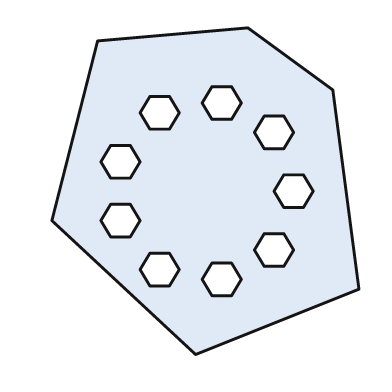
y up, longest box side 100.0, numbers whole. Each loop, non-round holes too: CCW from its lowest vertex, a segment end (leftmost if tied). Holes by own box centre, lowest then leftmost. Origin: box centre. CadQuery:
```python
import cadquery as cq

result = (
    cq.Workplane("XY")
    .moveTo(-3.0, -50.0)
    .lineTo(47.0, -30.0)
    .lineTo(39.0, 31.0)
    .lineTo(13.0, 50.0)
    .lineTo(-33.0, 46.0)
    .lineTo(-47.0, -9.0)
    .close()
    .moveTo(2.0, -32.0)
    .lineTo(8.0, -32.0)
    .lineTo(11.0, -27.0)
    .lineTo(8.0, -22.0)
    .lineTo(2.0, -22.0)
    .lineTo(-1.0, -27.0)
    .close()
    .moveTo(-17.0, -29.0)
    .lineTo(-11.0, -29.0)
    .lineTo(-8.0, -24.0)
    .lineTo(-11.0, -19.0)
    .lineTo(-17.0, -19.0)
    .lineTo(-20.0, -24.0)
    .close()
    .moveTo(18.0, -23.0)
    .lineTo(24.0, -23.0)
    .lineTo(27.0, -18.0)
    .lineTo(24.0, -13.0)
    .lineTo(18.0, -13.0)
    .lineTo(15.0, -18.0)
    .close()
    .moveTo(-29.0, -14.0)
    .lineTo(-23.0, -14.0)
    .lineTo(-20.0, -9.0)
    .lineTo(-23.0, -4.0)
    .lineTo(-29.0, -4.0)
    .lineTo(-32.0, -9.0)
    .close()
    .moveTo(24.0, -5.0)
    .lineTo(30.0, -5.0)
    .lineTo(33.0, 0.0)
    .lineTo(30.0, 5.0)
    .lineTo(24.0, 5.0)
    .lineTo(21.0, 0.0)
    .close()
    .moveTo(-29.0, 4.0)
    .lineTo(-23.0, 4.0)
    .lineTo(-20.0, 9.0)
    .lineTo(-23.0, 14.0)
    .lineTo(-29.0, 14.0)
    .lineTo(-32.0, 9.0)
    .close()
    .moveTo(18.0, 13.0)
    .lineTo(24.0, 13.0)
    .lineTo(27.0, 18.0)
    .lineTo(24.0, 23.0)
    .lineTo(18.0, 23.0)
    .lineTo(15.0, 18.0)
    .close()
    .moveTo(-17.0, 19.0)
    .lineTo(-11.0, 19.0)
    .lineTo(-8.0, 24.0)
    .lineTo(-11.0, 29.0)
    .lineTo(-17.0, 29.0)
    .lineTo(-20.0, 24.0)
    .close()
    .moveTo(2.0, 22.0)
    .lineTo(8.0, 22.0)
    .lineTo(11.0, 27.0)
    .lineTo(8.0, 32.0)
    .lineTo(2.0, 32.0)
    .lineTo(-1.0, 27.0)
    .close()
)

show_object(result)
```